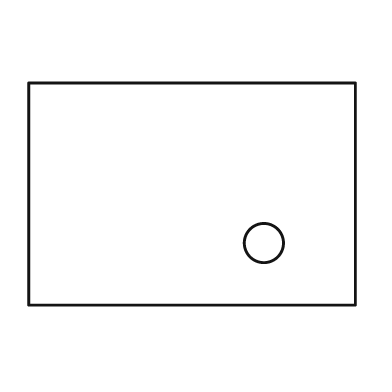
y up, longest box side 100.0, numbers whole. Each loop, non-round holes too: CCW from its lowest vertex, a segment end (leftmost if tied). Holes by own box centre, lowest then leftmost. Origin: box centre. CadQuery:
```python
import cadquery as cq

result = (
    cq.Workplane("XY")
    .moveTo(-50.0, -34.0)
    .lineTo(50.0, -34.0)
    .lineTo(50.0, 34.0)
    .lineTo(-50.0, 34.0)
    .close()
    .moveTo(22.0, -15.0)
    .circle(6.0)
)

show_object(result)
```